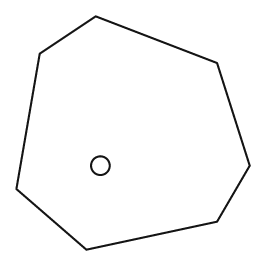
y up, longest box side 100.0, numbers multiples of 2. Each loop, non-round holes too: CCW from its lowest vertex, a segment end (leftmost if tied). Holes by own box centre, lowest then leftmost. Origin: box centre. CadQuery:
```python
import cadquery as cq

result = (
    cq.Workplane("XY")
    .moveTo(-20.0, -50.0)
    .lineTo(36.0, -38.0)
    .lineTo(50.0, -14.0)
    .lineTo(36.0, 30.0)
    .lineTo(-16.0, 50.0)
    .lineTo(-40.0, 34.0)
    .lineTo(-50.0, -24.0)
    .close()
    .moveTo(-14.0, -14.0)
    .circle(4.0)
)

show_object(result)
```